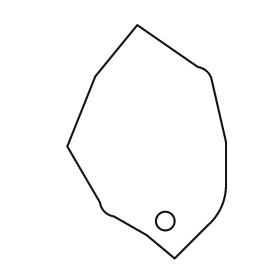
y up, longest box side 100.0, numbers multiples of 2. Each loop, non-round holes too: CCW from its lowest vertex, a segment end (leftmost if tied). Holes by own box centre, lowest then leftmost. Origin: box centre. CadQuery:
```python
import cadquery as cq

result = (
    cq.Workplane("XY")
    .moveTo(12.0, -50.0)
    .lineTo(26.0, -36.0)
    .threePointArc((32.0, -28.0), (34.0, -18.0))
    .lineTo(34.0, 0.0)
    .lineTo(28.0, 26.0)
    .threePointArc((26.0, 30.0), (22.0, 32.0))
    .lineTo(-4.0, 50.0)
    .lineTo(-22.0, 28.0)
    .lineTo(-34.0, -2.0)
    .lineTo(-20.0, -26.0)
    .threePointArc((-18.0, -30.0), (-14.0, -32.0))
    .lineTo(0.0, -40.0)
    .close()
    .moveTo(8.0, -34.0)
    .circle(4.0)
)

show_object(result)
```